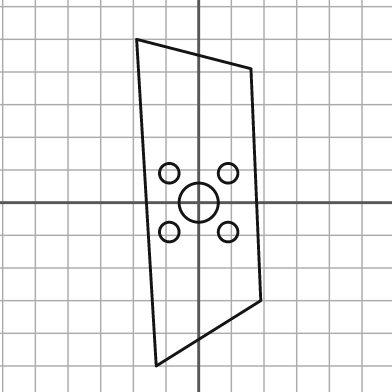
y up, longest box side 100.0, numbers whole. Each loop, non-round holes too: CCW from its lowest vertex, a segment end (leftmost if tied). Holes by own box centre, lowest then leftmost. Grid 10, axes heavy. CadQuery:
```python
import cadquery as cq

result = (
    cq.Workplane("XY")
    .moveTo(-13.0, -50.0)
    .lineTo(19.0, -30.0)
    .lineTo(16.0, 41.0)
    .lineTo(-19.0, 50.0)
    .close()
    .moveTo(-9.0, -9.0)
    .circle(3.0)
    .moveTo(9.0, -9.0)
    .circle(3.0)
    .moveTo(0.0, 0.0)
    .circle(6.0)
    .moveTo(-9.0, 9.0)
    .circle(3.0)
    .moveTo(9.0, 9.0)
    .circle(3.0)
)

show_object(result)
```